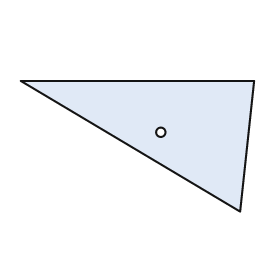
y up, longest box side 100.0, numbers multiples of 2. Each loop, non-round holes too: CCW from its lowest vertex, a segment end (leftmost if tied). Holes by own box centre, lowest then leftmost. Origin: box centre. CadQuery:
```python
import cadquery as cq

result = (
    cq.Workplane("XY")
    .moveTo(44.0, -28.0)
    .lineTo(50.0, 28.0)
    .lineTo(-50.0, 28.0)
    .close()
    .moveTo(10.0, 6.0)
    .circle(2.0)
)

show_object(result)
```